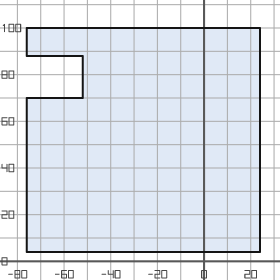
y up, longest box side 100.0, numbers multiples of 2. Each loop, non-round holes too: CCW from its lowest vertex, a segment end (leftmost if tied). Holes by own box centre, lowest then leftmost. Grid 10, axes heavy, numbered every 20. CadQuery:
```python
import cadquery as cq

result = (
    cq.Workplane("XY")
    .moveTo(-76.0, 4.0)
    .lineTo(24.0, 4.0)
    .lineTo(24.0, 100.0)
    .lineTo(-76.0, 100.0)
    .lineTo(-76.0, 88.0)
    .lineTo(-52.0, 88.0)
    .lineTo(-52.0, 70.0)
    .lineTo(-76.0, 70.0)
    .close()
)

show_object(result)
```